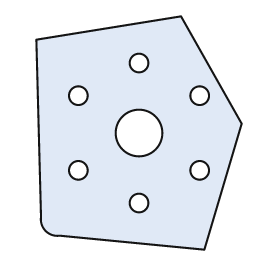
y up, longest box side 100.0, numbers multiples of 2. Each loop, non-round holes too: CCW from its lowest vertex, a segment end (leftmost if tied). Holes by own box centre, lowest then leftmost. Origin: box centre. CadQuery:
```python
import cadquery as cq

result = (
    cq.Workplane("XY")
    .moveTo(28.0, -50.0)
    .lineTo(44.0, 4.0)
    .lineTo(18.0, 50.0)
    .lineTo(-44.0, 40.0)
    .lineTo(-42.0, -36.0)
    .threePointArc((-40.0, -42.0), (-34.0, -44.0))
    .close()
    .moveTo(0.0, -30.0)
    .circle(4.0)
    .moveTo(-26.0, -16.0)
    .circle(4.0)
    .moveTo(26.0, -16.0)
    .circle(4.0)
    .moveTo(0.0, 0.0)
    .circle(10.0)
    .moveTo(-26.0, 16.0)
    .circle(4.0)
    .moveTo(26.0, 16.0)
    .circle(4.0)
    .moveTo(0.0, 30.0)
    .circle(4.0)
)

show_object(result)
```